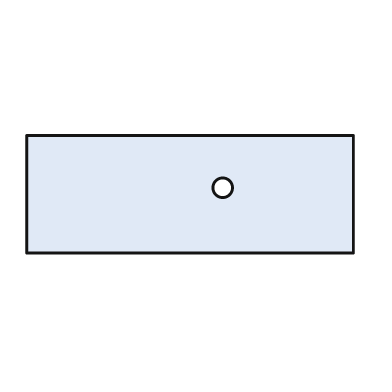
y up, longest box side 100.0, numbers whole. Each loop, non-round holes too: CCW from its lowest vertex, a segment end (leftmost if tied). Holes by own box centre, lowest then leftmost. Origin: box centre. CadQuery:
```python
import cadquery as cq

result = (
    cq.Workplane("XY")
    .moveTo(-50.0, -18.0)
    .lineTo(50.0, -18.0)
    .lineTo(50.0, 18.0)
    .lineTo(-50.0, 18.0)
    .close()
    .moveTo(10.0, 2.0)
    .circle(3.0)
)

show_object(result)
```